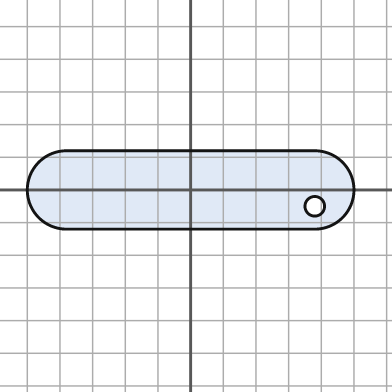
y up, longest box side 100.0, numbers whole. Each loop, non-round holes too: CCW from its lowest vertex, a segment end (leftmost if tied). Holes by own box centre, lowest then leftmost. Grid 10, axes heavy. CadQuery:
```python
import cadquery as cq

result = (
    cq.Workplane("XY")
    .moveTo(-38.0, -12.0)
    .lineTo(38.0, -12.0)
    .threePointArc((50.0, 0.0), (38.0, 12.0))
    .lineTo(-38.0, 12.0)
    .threePointArc((-50.0, 0.0), (-38.0, -12.0))
    .close()
    .moveTo(38.0, -5.0)
    .circle(3.0)
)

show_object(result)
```